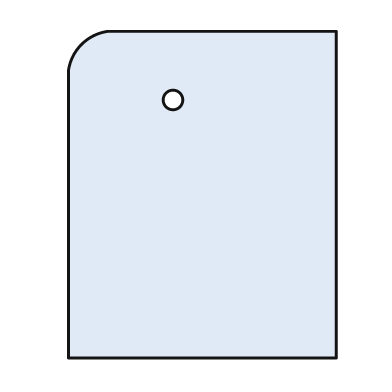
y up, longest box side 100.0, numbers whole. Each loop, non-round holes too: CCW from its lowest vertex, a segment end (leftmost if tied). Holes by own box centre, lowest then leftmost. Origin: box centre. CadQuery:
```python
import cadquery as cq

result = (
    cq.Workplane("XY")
    .moveTo(-41.0, -50.0)
    .lineTo(41.0, -50.0)
    .lineTo(41.0, 50.0)
    .lineTo(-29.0, 50.0)
    .threePointArc((-37.0, 46.0), (-41.0, 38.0))
    .close()
    .moveTo(-9.0, 29.0)
    .circle(3.0)
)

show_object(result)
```